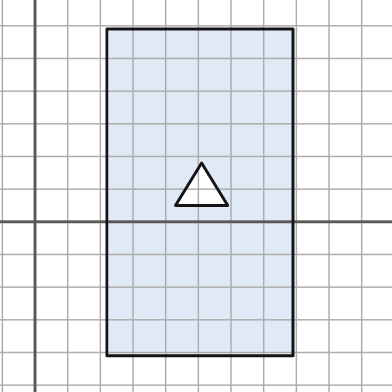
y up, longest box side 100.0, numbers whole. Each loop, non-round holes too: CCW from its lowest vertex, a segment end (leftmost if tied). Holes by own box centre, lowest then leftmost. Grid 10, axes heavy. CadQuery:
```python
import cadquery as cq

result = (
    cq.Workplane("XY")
    .moveTo(22.0, -41.0)
    .lineTo(79.0, -41.0)
    .lineTo(79.0, 59.0)
    .lineTo(22.0, 59.0)
    .close()
    .moveTo(43.0, 5.0)
    .lineTo(59.0, 5.0)
    .lineTo(51.0, 18.0)
    .close()
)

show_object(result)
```